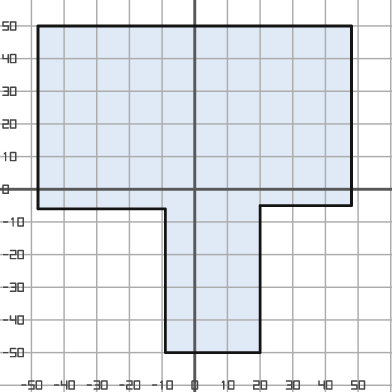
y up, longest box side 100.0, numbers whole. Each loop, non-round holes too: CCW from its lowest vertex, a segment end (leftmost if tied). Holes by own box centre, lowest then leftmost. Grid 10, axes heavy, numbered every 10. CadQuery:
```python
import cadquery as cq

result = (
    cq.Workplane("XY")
    .moveTo(-9.0, -50.0)
    .lineTo(20.0, -50.0)
    .lineTo(20.0, -5.0)
    .lineTo(48.0, -5.0)
    .lineTo(48.0, 50.0)
    .lineTo(-48.0, 50.0)
    .lineTo(-48.0, -6.0)
    .lineTo(-9.0, -6.0)
    .close()
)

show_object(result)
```